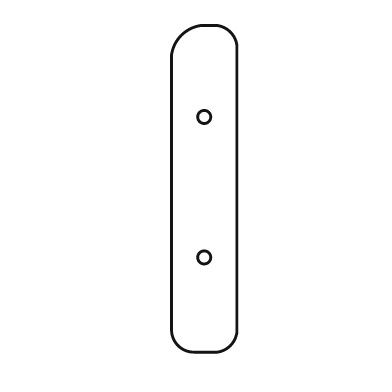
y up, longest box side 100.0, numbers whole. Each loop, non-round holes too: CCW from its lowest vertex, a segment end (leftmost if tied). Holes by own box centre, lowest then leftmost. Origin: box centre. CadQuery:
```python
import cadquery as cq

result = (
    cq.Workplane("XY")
    .moveTo(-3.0, -50.0)
    .lineTo(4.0, -50.0)
    .threePointArc((8.0, -48.0), (10.0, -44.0))
    .lineTo(10.0, 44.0)
    .threePointArc((8.0, 48.0), (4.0, 50.0))
    .lineTo(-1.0, 50.0)
    .threePointArc((-7.0, 47.0), (-10.0, 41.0))
    .lineTo(-10.0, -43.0)
    .threePointArc((-8.0, -48.0), (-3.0, -50.0))
    .close()
    .moveTo(0.0, -21.0)
    .circle(2.0)
    .moveTo(0.0, 22.0)
    .circle(2.0)
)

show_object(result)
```